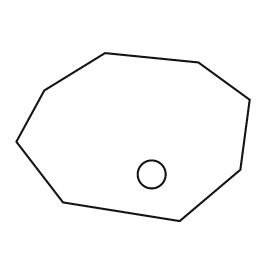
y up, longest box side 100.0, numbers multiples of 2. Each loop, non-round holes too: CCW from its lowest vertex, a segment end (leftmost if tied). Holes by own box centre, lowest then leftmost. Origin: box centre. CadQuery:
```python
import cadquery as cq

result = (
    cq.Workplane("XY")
    .moveTo(20.0, -36.0)
    .lineTo(46.0, -14.0)
    .lineTo(50.0, 16.0)
    .lineTo(28.0, 32.0)
    .lineTo(-12.0, 36.0)
    .lineTo(-38.0, 20.0)
    .lineTo(-50.0, -2.0)
    .lineTo(-30.0, -28.0)
    .close()
    .moveTo(8.0, -16.0)
    .circle(6.0)
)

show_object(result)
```